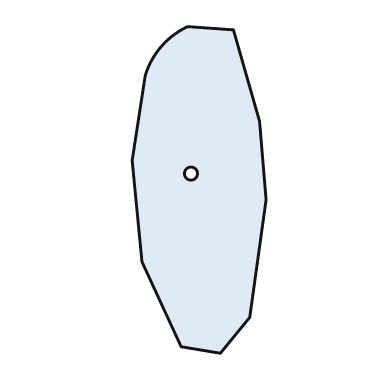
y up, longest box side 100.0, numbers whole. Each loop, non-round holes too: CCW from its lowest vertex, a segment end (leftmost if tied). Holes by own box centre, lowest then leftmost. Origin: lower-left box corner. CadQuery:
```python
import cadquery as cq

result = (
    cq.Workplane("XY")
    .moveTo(27.0, 0.0)
    .lineTo(36.0, 11.0)
    .lineTo(41.0, 47.0)
    .lineTo(39.0, 71.0)
    .lineTo(31.0, 99.0)
    .lineTo(17.0, 100.0)
    .threePointArc((9.0, 94.0), (4.0, 85.0))
    .lineTo(0.0, 59.0)
    .lineTo(3.0, 28.0)
    .lineTo(15.0, 2.0)
    .close()
    .moveTo(18.0, 55.0)
    .circle(2.0)
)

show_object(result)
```